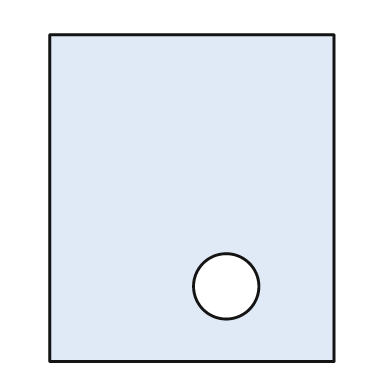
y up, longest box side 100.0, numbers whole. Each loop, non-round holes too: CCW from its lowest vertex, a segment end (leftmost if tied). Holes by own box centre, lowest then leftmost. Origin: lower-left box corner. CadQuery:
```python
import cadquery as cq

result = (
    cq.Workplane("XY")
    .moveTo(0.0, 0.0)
    .lineTo(87.0, 0.0)
    .lineTo(87.0, 100.0)
    .lineTo(0.0, 100.0)
    .close()
    .moveTo(54.0, 23.0)
    .circle(10.0)
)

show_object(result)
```